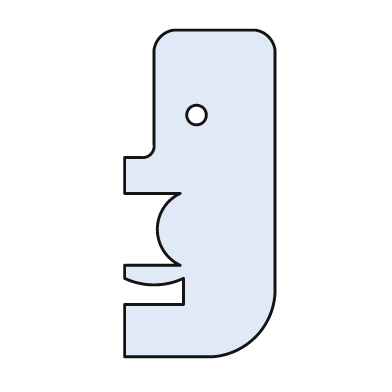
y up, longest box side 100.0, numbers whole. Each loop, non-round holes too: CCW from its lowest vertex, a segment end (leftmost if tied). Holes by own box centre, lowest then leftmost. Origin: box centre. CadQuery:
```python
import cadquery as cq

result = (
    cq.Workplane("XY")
    .moveTo(-23.0, -50.0)
    .lineTo(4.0, -50.0)
    .threePointArc((17.0, -44.0), (23.0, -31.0))
    .lineTo(23.0, 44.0)
    .threePointArc((21.0, 48.0), (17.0, 50.0))
    .lineTo(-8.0, 50.0)
    .threePointArc((-12.0, 48.0), (-14.0, 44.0))
    .lineTo(-14.0, 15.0)
    .threePointArc((-15.0, 12.0), (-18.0, 11.0))
    .lineTo(-23.0, 11.0)
    .lineTo(-23.0, 0.0)
    .lineTo(-6.0, 0.0)
    .threePointArc((-13.0, -11.0), (-6.0, -22.0))
    .lineTo(-23.0, -22.0)
    .lineTo(-23.0, -26.0)
    .threePointArc((-14.0, -28.0), (-5.0, -26.0))
    .lineTo(-5.0, -34.0)
    .lineTo(-23.0, -34.0)
    .close()
    .moveTo(-1.0, 24.0)
    .circle(3.0)
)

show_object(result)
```